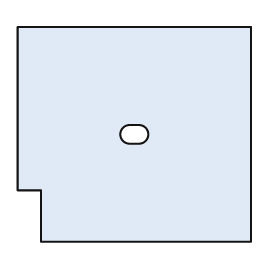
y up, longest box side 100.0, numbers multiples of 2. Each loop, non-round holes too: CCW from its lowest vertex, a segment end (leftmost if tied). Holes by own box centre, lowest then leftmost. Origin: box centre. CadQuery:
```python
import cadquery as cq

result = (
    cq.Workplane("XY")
    .moveTo(-40.0, -46.0)
    .lineTo(50.0, -46.0)
    .lineTo(50.0, 46.0)
    .lineTo(-50.0, 46.0)
    .lineTo(-50.0, -24.0)
    .lineTo(-40.0, -24.0)
    .close()
    .moveTo(-2.0, -4.0)
    .lineTo(2.0, -4.0)
    .threePointArc((6.0, 0.0), (2.0, 4.0))
    .lineTo(-2.0, 4.0)
    .threePointArc((-6.0, 0.0), (-2.0, -4.0))
    .close()
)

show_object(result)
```